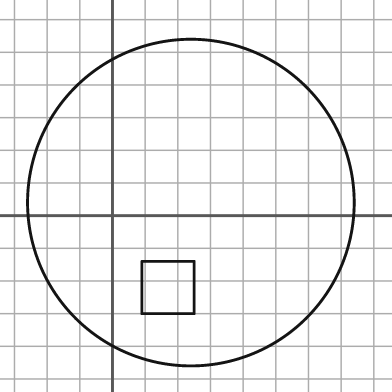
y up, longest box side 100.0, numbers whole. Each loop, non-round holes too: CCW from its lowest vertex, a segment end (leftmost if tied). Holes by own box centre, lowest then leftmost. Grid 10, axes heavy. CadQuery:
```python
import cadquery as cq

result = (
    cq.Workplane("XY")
    .moveTo(24.0, 4.0)
    .circle(50.0)
    .moveTo(9.0, -30.0)
    .lineTo(25.0, -30.0)
    .lineTo(25.0, -14.0)
    .lineTo(9.0, -14.0)
    .close()
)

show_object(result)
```